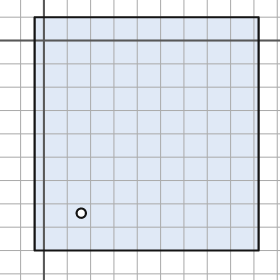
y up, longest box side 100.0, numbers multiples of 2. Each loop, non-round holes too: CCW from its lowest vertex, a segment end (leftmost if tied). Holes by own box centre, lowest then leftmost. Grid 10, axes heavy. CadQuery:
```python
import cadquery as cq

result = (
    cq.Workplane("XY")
    .moveTo(-4.0, -90.0)
    .lineTo(92.0, -90.0)
    .lineTo(92.0, 10.0)
    .lineTo(-4.0, 10.0)
    .close()
    .moveTo(16.0, -74.0)
    .circle(2.0)
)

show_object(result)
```